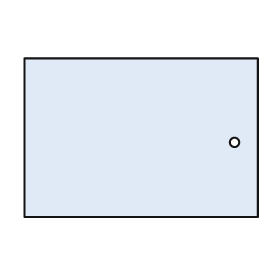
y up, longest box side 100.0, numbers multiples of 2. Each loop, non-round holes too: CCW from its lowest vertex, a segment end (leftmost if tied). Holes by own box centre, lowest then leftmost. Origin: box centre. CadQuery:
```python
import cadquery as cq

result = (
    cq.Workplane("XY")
    .moveTo(-50.0, -34.0)
    .lineTo(50.0, -34.0)
    .lineTo(50.0, 34.0)
    .lineTo(-50.0, 34.0)
    .close()
    .moveTo(40.0, -2.0)
    .circle(2.0)
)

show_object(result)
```